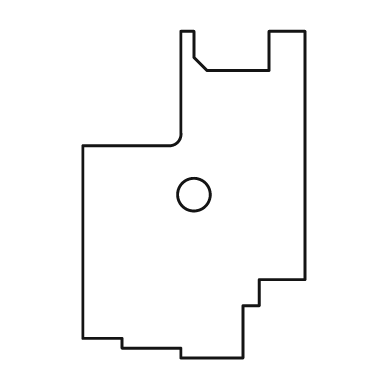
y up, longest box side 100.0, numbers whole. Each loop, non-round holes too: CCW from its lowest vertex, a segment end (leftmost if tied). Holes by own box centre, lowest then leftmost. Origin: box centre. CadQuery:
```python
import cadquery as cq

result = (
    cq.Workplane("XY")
    .moveTo(-4.0, -50.0)
    .lineTo(15.0, -50.0)
    .lineTo(15.0, -34.0)
    .lineTo(20.0, -34.0)
    .lineTo(20.0, -26.0)
    .lineTo(34.0, -26.0)
    .lineTo(34.0, 50.0)
    .lineTo(23.0, 50.0)
    .lineTo(23.0, 38.0)
    .lineTo(4.0, 38.0)
    .lineTo(0.0, 42.0)
    .lineTo(0.0, 50.0)
    .lineTo(-4.0, 50.0)
    .lineTo(-4.0, 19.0)
    .threePointArc((-5.0, 16.0), (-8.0, 15.0))
    .lineTo(-34.0, 15.0)
    .lineTo(-34.0, -44.0)
    .lineTo(-22.0, -44.0)
    .lineTo(-22.0, -47.0)
    .lineTo(-4.0, -47.0)
    .close()
    .moveTo(0.0, 0.0)
    .circle(5.0)
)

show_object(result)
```